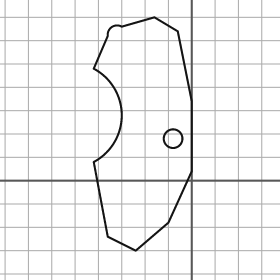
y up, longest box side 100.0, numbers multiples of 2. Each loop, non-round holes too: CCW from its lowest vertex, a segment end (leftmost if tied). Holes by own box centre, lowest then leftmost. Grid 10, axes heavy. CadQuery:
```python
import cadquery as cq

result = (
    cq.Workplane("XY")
    .moveTo(-24.0, -30.0)
    .lineTo(-10.0, -18.0)
    .lineTo(0.0, 4.0)
    .lineTo(0.0, 34.0)
    .lineTo(-6.0, 64.0)
    .lineTo(-16.0, 70.0)
    .lineTo(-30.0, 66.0)
    .threePointArc((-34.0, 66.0), (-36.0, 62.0))
    .lineTo(-42.0, 48.0)
    .threePointArc((-30.0, 28.0), (-42.0, 8.0))
    .lineTo(-36.0, -24.0)
    .close()
    .moveTo(-8.0, 18.0)
    .circle(4.0)
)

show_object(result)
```